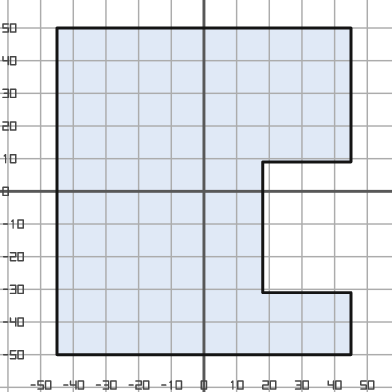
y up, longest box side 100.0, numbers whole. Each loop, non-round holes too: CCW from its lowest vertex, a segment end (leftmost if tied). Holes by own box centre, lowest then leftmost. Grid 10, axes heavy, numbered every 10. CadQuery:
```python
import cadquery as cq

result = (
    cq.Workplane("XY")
    .moveTo(-45.0, -50.0)
    .lineTo(45.0, -50.0)
    .lineTo(45.0, -31.0)
    .lineTo(18.0, -31.0)
    .lineTo(18.0, 9.0)
    .lineTo(45.0, 9.0)
    .lineTo(45.0, 50.0)
    .lineTo(-45.0, 50.0)
    .close()
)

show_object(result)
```